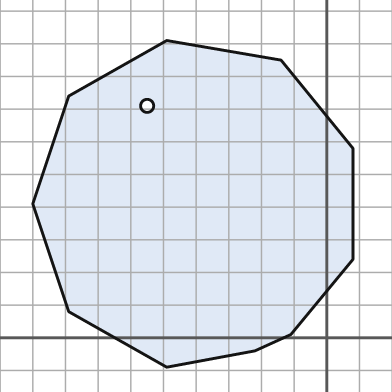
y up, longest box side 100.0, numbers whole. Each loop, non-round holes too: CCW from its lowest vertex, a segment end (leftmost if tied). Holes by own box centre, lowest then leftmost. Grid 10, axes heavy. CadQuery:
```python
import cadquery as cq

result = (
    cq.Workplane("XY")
    .moveTo(-49.0, -9.0)
    .lineTo(-22.0, -4.0)
    .lineTo(-11.0, 1.0)
    .lineTo(8.0, 24.0)
    .lineTo(8.0, 58.0)
    .lineTo(-14.0, 85.0)
    .lineTo(-49.0, 91.0)
    .lineTo(-79.0, 74.0)
    .lineTo(-90.0, 41.0)
    .lineTo(-79.0, 8.0)
    .close()
    .moveTo(-55.0, 71.0)
    .circle(2.0)
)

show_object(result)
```